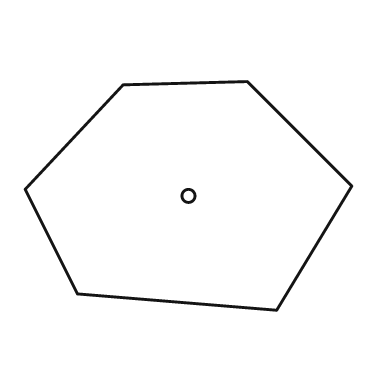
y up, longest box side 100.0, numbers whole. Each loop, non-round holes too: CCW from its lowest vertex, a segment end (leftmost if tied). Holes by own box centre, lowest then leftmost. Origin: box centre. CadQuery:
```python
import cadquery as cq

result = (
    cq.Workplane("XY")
    .moveTo(27.0, -35.0)
    .lineTo(50.0, 3.0)
    .lineTo(18.0, 35.0)
    .lineTo(-20.0, 34.0)
    .lineTo(-50.0, 2.0)
    .lineTo(-34.0, -30.0)
    .close()
    .moveTo(0.0, 0.0)
    .circle(2.0)
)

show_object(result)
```